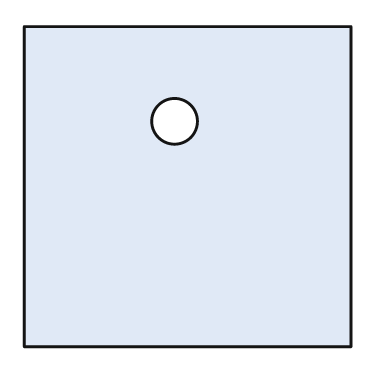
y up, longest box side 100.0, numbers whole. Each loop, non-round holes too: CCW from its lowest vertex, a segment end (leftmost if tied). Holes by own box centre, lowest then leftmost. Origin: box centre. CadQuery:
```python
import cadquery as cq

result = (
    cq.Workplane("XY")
    .moveTo(-50.0, -49.0)
    .lineTo(50.0, -49.0)
    .lineTo(50.0, 49.0)
    .lineTo(-50.0, 49.0)
    .close()
    .moveTo(-4.0, 20.0)
    .circle(7.0)
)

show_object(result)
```